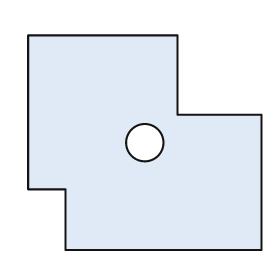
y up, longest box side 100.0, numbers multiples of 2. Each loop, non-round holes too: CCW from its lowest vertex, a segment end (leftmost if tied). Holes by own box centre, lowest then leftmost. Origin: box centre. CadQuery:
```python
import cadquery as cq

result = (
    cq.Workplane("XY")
    .moveTo(-34.0, -46.0)
    .lineTo(50.0, -46.0)
    .lineTo(50.0, 12.0)
    .lineTo(14.0, 12.0)
    .lineTo(14.0, 46.0)
    .lineTo(-50.0, 46.0)
    .lineTo(-50.0, -20.0)
    .lineTo(-34.0, -20.0)
    .close()
    .moveTo(0.0, 0.0)
    .circle(8.0)
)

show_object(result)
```